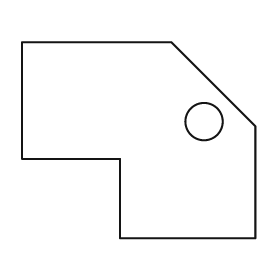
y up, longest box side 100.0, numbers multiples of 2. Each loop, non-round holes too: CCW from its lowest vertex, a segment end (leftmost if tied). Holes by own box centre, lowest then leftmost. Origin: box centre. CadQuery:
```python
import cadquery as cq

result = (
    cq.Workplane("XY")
    .moveTo(-8.0, -42.0)
    .lineTo(50.0, -42.0)
    .lineTo(50.0, 6.0)
    .lineTo(14.0, 42.0)
    .lineTo(-50.0, 42.0)
    .lineTo(-50.0, -8.0)
    .lineTo(-8.0, -8.0)
    .close()
    .moveTo(28.0, 8.0)
    .circle(8.0)
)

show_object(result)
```